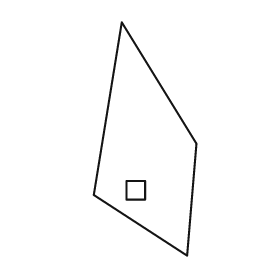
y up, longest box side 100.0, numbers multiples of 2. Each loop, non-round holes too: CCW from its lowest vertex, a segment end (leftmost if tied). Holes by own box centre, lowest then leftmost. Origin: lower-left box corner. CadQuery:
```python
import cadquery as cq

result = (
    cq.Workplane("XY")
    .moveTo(40.0, 0.0)
    .lineTo(44.0, 48.0)
    .lineTo(12.0, 100.0)
    .lineTo(0.0, 26.0)
    .close()
    .moveTo(14.0, 24.0)
    .lineTo(22.0, 24.0)
    .lineTo(22.0, 32.0)
    .lineTo(14.0, 32.0)
    .close()
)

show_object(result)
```